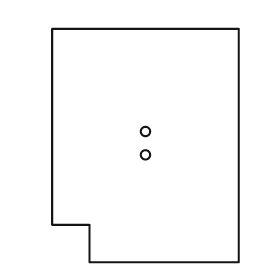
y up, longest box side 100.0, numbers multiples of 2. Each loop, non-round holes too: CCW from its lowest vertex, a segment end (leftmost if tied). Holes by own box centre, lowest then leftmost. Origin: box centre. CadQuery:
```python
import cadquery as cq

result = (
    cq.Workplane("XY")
    .moveTo(-24.0, -50.0)
    .lineTo(40.0, -50.0)
    .lineTo(40.0, 50.0)
    .lineTo(-40.0, 50.0)
    .lineTo(-40.0, -34.0)
    .lineTo(-24.0, -34.0)
    .close()
    .moveTo(0.0, -4.0)
    .circle(2.0)
    .moveTo(0.0, 6.0)
    .circle(2.0)
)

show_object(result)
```